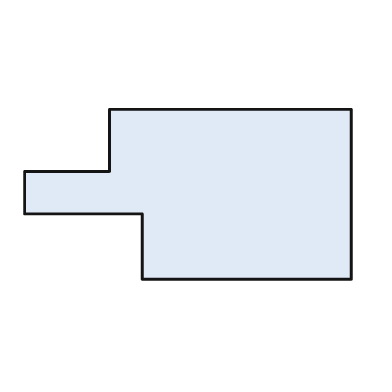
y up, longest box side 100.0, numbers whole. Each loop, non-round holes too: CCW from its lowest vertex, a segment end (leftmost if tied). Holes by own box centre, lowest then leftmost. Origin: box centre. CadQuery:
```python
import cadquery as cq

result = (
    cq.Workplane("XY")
    .moveTo(-14.0, -26.0)
    .lineTo(50.0, -26.0)
    .lineTo(50.0, 26.0)
    .lineTo(-24.0, 26.0)
    .lineTo(-24.0, 7.0)
    .lineTo(-50.0, 7.0)
    .lineTo(-50.0, -6.0)
    .lineTo(-14.0, -6.0)
    .close()
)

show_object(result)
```